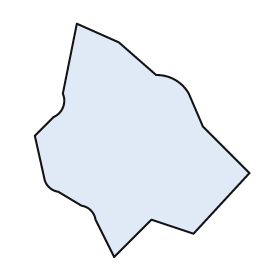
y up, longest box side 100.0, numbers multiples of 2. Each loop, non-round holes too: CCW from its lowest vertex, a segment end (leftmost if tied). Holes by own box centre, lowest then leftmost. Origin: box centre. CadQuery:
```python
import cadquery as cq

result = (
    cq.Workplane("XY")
    .moveTo(-12.0, -50.0)
    .lineTo(4.0, -34.0)
    .lineTo(22.0, -40.0)
    .lineTo(46.0, -14.0)
    .lineTo(26.0, 6.0)
    .lineTo(20.0, 20.0)
    .threePointArc((14.0, 26.0), (6.0, 28.0))
    .lineTo(-10.0, 42.0)
    .lineTo(-28.0, 50.0)
    .lineTo(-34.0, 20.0)
    .threePointArc((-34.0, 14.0), (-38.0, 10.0))
    .lineTo(-46.0, 2.0)
    .lineTo(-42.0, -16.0)
    .threePointArc((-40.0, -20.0), (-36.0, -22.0))
    .lineTo(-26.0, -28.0)
    .threePointArc((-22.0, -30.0), (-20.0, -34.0))
    .close()
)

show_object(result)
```